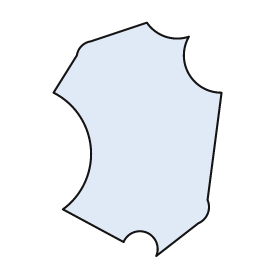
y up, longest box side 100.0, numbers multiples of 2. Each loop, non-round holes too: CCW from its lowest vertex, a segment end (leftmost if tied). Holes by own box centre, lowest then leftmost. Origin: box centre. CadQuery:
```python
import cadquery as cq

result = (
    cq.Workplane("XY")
    .moveTo(8.0, -50.0)
    .lineTo(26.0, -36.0)
    .threePointArc((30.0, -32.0), (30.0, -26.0))
    .lineTo(36.0, 20.0)
    .threePointArc((22.0, 28.0), (22.0, 44.0))
    .threePointArc((12.0, 44.0), (4.0, 50.0))
    .lineTo(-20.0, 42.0)
    .threePointArc((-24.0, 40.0), (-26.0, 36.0))
    .lineTo(-36.0, 20.0)
    .threePointArc((-20.0, -4.0), (-32.0, -30.0))
    .lineTo(-6.0, -44.0)
    .threePointArc((4.0, -40.0), (8.0, -50.0))
    .close()
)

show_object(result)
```